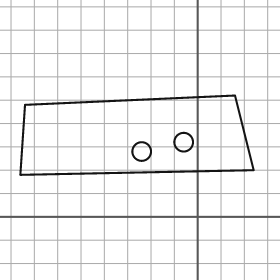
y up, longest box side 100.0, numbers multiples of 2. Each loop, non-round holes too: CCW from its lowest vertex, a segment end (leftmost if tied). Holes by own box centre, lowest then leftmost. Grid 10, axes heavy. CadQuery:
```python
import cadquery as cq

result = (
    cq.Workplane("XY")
    .moveTo(-76.0, 18.0)
    .lineTo(24.0, 20.0)
    .lineTo(16.0, 52.0)
    .lineTo(-74.0, 48.0)
    .close()
    .moveTo(-24.0, 28.0)
    .circle(4.0)
    .moveTo(-6.0, 32.0)
    .circle(4.0)
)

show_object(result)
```